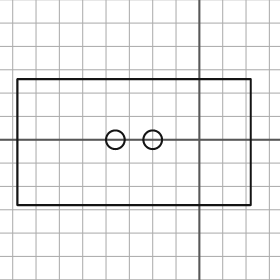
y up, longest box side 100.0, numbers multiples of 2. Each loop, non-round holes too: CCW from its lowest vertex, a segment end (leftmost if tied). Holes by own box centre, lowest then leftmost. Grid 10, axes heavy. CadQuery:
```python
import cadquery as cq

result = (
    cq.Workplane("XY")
    .moveTo(-78.0, -28.0)
    .lineTo(22.0, -28.0)
    .lineTo(22.0, 26.0)
    .lineTo(-78.0, 26.0)
    .close()
    .moveTo(-36.0, 0.0)
    .circle(4.0)
    .moveTo(-20.0, 0.0)
    .circle(4.0)
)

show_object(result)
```